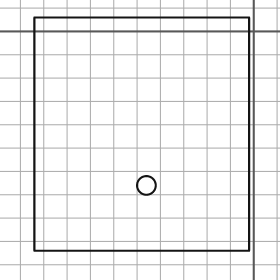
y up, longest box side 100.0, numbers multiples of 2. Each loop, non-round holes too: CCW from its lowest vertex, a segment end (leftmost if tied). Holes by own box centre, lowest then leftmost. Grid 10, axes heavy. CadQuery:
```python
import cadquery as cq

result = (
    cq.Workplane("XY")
    .moveTo(-94.0, -94.0)
    .lineTo(-2.0, -94.0)
    .lineTo(-2.0, 6.0)
    .lineTo(-94.0, 6.0)
    .close()
    .moveTo(-46.0, -66.0)
    .circle(4.0)
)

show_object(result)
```